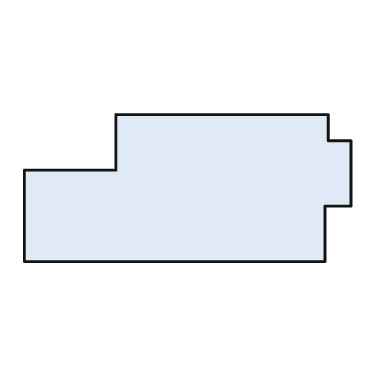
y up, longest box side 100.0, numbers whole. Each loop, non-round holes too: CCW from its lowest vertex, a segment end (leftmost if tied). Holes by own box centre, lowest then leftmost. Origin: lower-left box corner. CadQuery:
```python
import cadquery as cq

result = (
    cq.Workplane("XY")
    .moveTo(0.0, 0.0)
    .lineTo(92.0, 0.0)
    .lineTo(92.0, 17.0)
    .lineTo(100.0, 17.0)
    .lineTo(100.0, 37.0)
    .lineTo(93.0, 37.0)
    .lineTo(93.0, 45.0)
    .lineTo(28.0, 45.0)
    .lineTo(28.0, 28.0)
    .lineTo(0.0, 28.0)
    .close()
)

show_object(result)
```